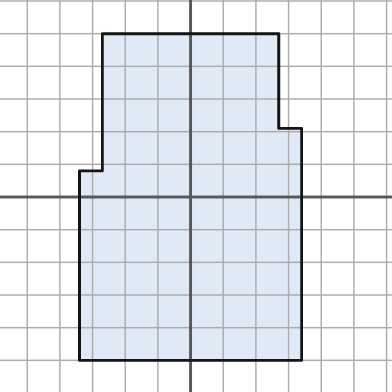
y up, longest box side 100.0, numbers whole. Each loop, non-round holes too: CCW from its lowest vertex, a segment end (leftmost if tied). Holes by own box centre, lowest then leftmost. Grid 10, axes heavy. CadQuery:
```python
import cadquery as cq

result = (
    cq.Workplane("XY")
    .moveTo(-34.0, -50.0)
    .lineTo(34.0, -50.0)
    .lineTo(34.0, 21.0)
    .lineTo(27.0, 21.0)
    .lineTo(27.0, 50.0)
    .lineTo(-27.0, 50.0)
    .lineTo(-27.0, 8.0)
    .lineTo(-34.0, 8.0)
    .close()
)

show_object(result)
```